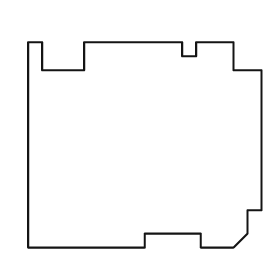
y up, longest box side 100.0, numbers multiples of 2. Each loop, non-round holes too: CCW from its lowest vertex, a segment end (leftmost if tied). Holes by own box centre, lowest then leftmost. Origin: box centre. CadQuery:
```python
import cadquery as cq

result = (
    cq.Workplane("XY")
    .moveTo(-50.0, -44.0)
    .lineTo(0.0, -44.0)
    .lineTo(0.0, -38.0)
    .lineTo(24.0, -38.0)
    .lineTo(24.0, -44.0)
    .lineTo(38.0, -44.0)
    .lineTo(44.0, -38.0)
    .lineTo(44.0, -28.0)
    .lineTo(50.0, -28.0)
    .lineTo(50.0, 32.0)
    .lineTo(38.0, 32.0)
    .lineTo(38.0, 44.0)
    .lineTo(22.0, 44.0)
    .lineTo(22.0, 38.0)
    .lineTo(16.0, 38.0)
    .lineTo(16.0, 44.0)
    .lineTo(-26.0, 44.0)
    .lineTo(-26.0, 32.0)
    .lineTo(-44.0, 32.0)
    .lineTo(-44.0, 44.0)
    .lineTo(-50.0, 44.0)
    .close()
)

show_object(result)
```